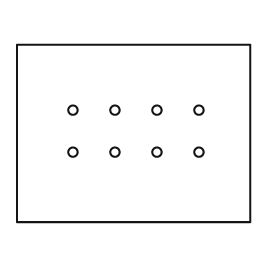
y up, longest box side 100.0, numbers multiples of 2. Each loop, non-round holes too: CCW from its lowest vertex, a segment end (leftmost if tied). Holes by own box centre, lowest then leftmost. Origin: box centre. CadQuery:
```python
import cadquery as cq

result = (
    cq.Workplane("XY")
    .moveTo(-50.0, -38.0)
    .lineTo(50.0, -38.0)
    .lineTo(50.0, 38.0)
    .lineTo(-50.0, 38.0)
    .close()
    .moveTo(-26.0, -8.0)
    .circle(2.0)
    .moveTo(-8.0, -8.0)
    .circle(2.0)
    .moveTo(10.0, -8.0)
    .circle(2.0)
    .moveTo(28.0, -8.0)
    .circle(2.0)
    .moveTo(-26.0, 10.0)
    .circle(2.0)
    .moveTo(-8.0, 10.0)
    .circle(2.0)
    .moveTo(10.0, 10.0)
    .circle(2.0)
    .moveTo(28.0, 10.0)
    .circle(2.0)
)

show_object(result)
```